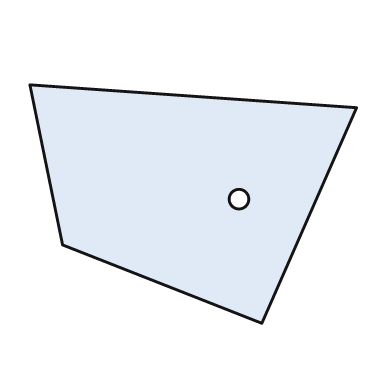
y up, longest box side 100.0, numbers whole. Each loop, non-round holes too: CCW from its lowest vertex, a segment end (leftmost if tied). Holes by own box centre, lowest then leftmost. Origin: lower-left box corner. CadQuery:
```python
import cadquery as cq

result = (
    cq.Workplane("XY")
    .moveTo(71.0, 0.0)
    .lineTo(100.0, 66.0)
    .lineTo(0.0, 73.0)
    .lineTo(10.0, 24.0)
    .close()
    .moveTo(64.0, 38.0)
    .circle(3.0)
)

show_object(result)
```